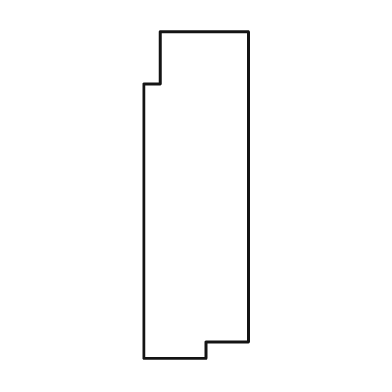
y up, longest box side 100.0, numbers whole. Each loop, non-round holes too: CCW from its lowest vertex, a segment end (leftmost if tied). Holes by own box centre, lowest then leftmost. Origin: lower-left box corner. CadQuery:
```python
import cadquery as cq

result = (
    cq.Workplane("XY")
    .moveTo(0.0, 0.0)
    .lineTo(19.0, 0.0)
    .lineTo(19.0, 5.0)
    .lineTo(32.0, 5.0)
    .lineTo(32.0, 100.0)
    .lineTo(5.0, 100.0)
    .lineTo(5.0, 84.0)
    .lineTo(0.0, 84.0)
    .close()
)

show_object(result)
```